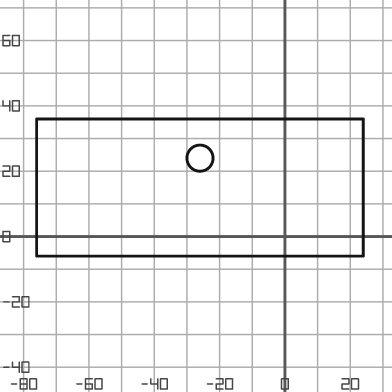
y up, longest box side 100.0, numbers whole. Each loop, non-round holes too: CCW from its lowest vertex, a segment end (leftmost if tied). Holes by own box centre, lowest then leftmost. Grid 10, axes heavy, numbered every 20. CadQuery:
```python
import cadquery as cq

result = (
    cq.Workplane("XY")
    .moveTo(-76.0, -6.0)
    .lineTo(24.0, -6.0)
    .lineTo(24.0, 36.0)
    .lineTo(-76.0, 36.0)
    .close()
    .moveTo(-26.0, 24.0)
    .circle(4.0)
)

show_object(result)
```